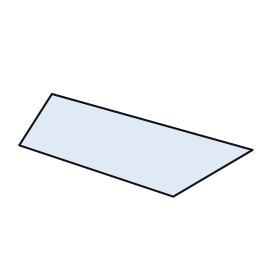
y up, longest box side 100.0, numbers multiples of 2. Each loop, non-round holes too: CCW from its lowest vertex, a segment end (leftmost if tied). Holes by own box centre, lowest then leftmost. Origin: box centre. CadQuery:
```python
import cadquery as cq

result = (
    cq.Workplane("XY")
    .moveTo(16.0, -22.0)
    .lineTo(50.0, -2.0)
    .lineTo(-36.0, 22.0)
    .lineTo(-50.0, 0.0)
    .close()
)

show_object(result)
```